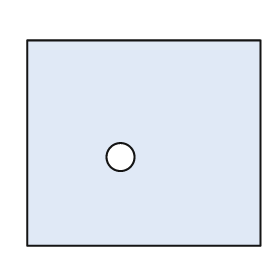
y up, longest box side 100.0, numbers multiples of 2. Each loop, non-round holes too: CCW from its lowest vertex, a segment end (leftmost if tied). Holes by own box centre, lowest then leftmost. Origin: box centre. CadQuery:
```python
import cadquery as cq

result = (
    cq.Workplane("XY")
    .moveTo(-50.0, -44.0)
    .lineTo(50.0, -44.0)
    .lineTo(50.0, 44.0)
    .lineTo(-50.0, 44.0)
    .close()
    .moveTo(-10.0, -6.0)
    .circle(6.0)
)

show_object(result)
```